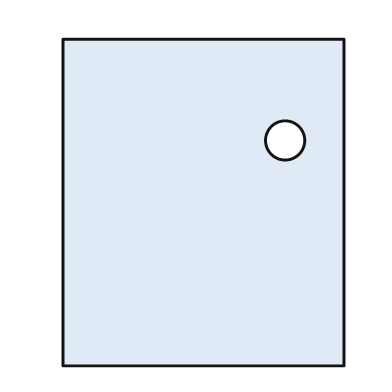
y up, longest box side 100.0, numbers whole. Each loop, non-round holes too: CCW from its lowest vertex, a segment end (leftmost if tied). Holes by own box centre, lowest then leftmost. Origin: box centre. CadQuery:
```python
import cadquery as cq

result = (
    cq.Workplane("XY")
    .moveTo(-43.0, -50.0)
    .lineTo(43.0, -50.0)
    .lineTo(43.0, 50.0)
    .lineTo(-43.0, 50.0)
    .close()
    .moveTo(25.0, 19.0)
    .circle(6.0)
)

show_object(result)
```